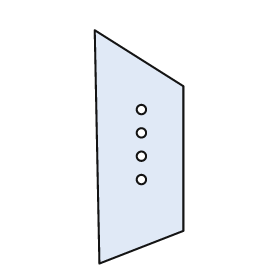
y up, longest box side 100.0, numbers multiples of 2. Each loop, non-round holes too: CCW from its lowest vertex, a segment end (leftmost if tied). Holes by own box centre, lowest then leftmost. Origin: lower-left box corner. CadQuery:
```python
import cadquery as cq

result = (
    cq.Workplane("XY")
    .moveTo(2.0, 0.0)
    .lineTo(38.0, 14.0)
    .lineTo(38.0, 76.0)
    .lineTo(0.0, 100.0)
    .close()
    .moveTo(20.0, 36.0)
    .circle(2.0)
    .moveTo(20.0, 46.0)
    .circle(2.0)
    .moveTo(20.0, 56.0)
    .circle(2.0)
    .moveTo(20.0, 66.0)
    .circle(2.0)
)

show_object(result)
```